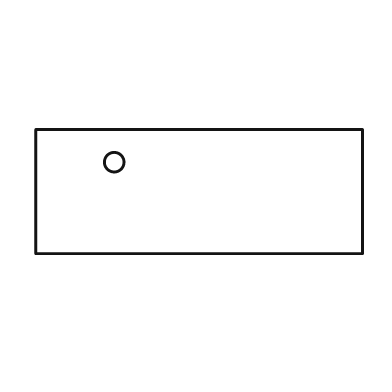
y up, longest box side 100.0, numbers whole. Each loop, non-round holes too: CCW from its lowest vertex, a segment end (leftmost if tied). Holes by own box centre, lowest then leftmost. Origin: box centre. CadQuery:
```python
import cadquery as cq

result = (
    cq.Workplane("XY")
    .moveTo(-50.0, -19.0)
    .lineTo(50.0, -19.0)
    .lineTo(50.0, 19.0)
    .lineTo(-50.0, 19.0)
    .close()
    .moveTo(-26.0, 9.0)
    .circle(3.0)
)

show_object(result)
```